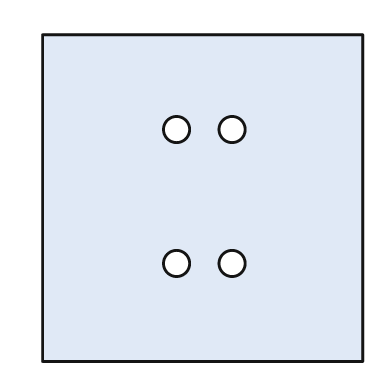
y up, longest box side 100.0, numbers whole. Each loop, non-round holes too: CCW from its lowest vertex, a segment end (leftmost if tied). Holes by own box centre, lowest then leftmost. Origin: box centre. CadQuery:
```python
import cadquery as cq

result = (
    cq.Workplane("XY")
    .moveTo(-49.0, -50.0)
    .lineTo(49.0, -50.0)
    .lineTo(49.0, 50.0)
    .lineTo(-49.0, 50.0)
    .close()
    .moveTo(-8.0, -20.0)
    .circle(4.0)
    .moveTo(9.0, -20.0)
    .circle(4.0)
    .moveTo(-8.0, 21.0)
    .circle(4.0)
    .moveTo(9.0, 21.0)
    .circle(4.0)
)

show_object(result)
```